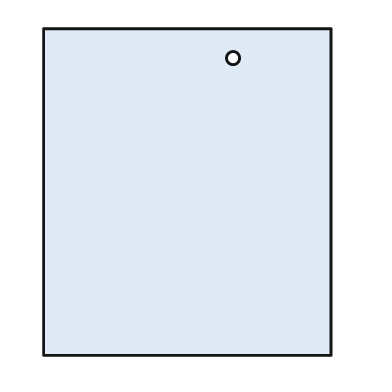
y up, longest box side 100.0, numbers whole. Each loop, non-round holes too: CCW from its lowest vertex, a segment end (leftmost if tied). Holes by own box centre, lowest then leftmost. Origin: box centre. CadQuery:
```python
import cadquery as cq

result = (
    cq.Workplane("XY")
    .moveTo(-44.0, -50.0)
    .lineTo(44.0, -50.0)
    .lineTo(44.0, 50.0)
    .lineTo(-44.0, 50.0)
    .close()
    .moveTo(14.0, 41.0)
    .circle(2.0)
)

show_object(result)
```